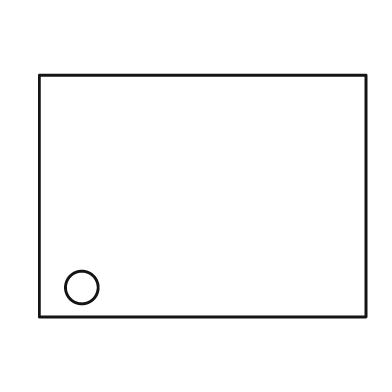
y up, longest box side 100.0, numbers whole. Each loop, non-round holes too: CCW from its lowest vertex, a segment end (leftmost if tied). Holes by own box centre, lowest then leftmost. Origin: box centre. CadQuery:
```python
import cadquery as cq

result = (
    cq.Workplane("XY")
    .moveTo(-50.0, -37.0)
    .lineTo(50.0, -37.0)
    .lineTo(50.0, 37.0)
    .lineTo(-50.0, 37.0)
    .close()
    .moveTo(-37.0, -28.0)
    .circle(5.0)
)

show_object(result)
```